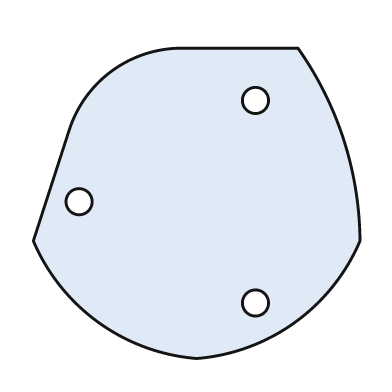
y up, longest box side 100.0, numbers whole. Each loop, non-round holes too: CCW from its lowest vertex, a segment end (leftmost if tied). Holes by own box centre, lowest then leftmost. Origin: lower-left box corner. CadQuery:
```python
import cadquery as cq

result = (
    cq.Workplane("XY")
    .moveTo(50.0, 0.0)
    .threePointArc((80.0, 11.0), (100.0, 36.0))
    .threePointArc((95.0, 67.0), (81.0, 95.0))
    .lineTo(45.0, 95.0)
    .threePointArc((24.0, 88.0), (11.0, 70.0))
    .lineTo(0.0, 36.0)
    .threePointArc((20.0, 11.0), (50.0, 0.0))
    .close()
    .moveTo(68.0, 17.0)
    .circle(4.0)
    .moveTo(14.0, 48.0)
    .circle(4.0)
    .moveTo(68.0, 79.0)
    .circle(4.0)
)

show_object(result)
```